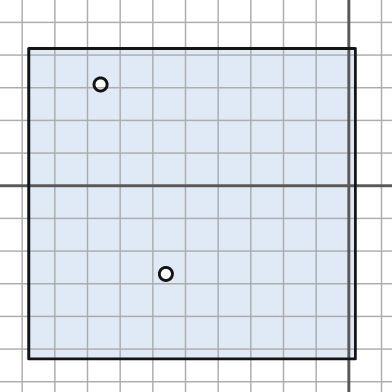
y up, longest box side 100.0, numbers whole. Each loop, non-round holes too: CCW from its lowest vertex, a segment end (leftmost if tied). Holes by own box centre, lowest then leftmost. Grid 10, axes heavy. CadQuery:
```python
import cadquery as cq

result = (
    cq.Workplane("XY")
    .moveTo(-98.0, -53.0)
    .lineTo(2.0, -53.0)
    .lineTo(2.0, 42.0)
    .lineTo(-98.0, 42.0)
    .close()
    .moveTo(-56.0, -27.0)
    .circle(2.0)
    .moveTo(-76.0, 31.0)
    .circle(2.0)
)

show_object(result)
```